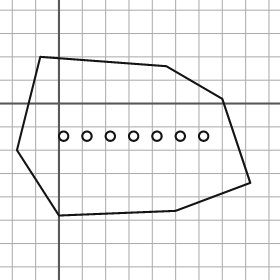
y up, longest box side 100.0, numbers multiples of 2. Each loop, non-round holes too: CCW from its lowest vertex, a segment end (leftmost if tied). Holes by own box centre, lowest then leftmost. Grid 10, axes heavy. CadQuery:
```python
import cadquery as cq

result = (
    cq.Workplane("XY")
    .moveTo(0.0, -48.0)
    .lineTo(50.0, -46.0)
    .lineTo(82.0, -34.0)
    .lineTo(70.0, 2.0)
    .lineTo(46.0, 16.0)
    .lineTo(-8.0, 20.0)
    .lineTo(-18.0, -20.0)
    .close()
    .moveTo(2.0, -14.0)
    .circle(2.0)
    .moveTo(12.0, -14.0)
    .circle(2.0)
    .moveTo(22.0, -14.0)
    .circle(2.0)
    .moveTo(32.0, -14.0)
    .circle(2.0)
    .moveTo(42.0, -14.0)
    .circle(2.0)
    .moveTo(52.0, -14.0)
    .circle(2.0)
    .moveTo(62.0, -14.0)
    .circle(2.0)
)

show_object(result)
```